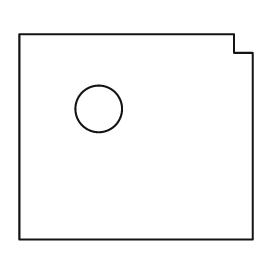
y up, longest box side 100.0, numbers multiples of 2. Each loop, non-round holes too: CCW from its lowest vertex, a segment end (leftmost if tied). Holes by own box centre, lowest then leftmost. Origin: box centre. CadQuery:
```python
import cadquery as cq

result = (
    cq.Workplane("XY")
    .moveTo(-50.0, -44.0)
    .lineTo(50.0, -44.0)
    .lineTo(50.0, 36.0)
    .lineTo(42.0, 36.0)
    .lineTo(42.0, 44.0)
    .lineTo(-50.0, 44.0)
    .close()
    .moveTo(-16.0, 12.0)
    .circle(10.0)
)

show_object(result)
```